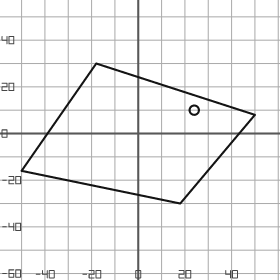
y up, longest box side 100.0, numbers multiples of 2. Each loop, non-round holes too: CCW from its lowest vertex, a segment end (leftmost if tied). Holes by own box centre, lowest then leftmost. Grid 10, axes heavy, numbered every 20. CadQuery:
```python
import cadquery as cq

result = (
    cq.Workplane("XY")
    .moveTo(18.0, -30.0)
    .lineTo(50.0, 8.0)
    .lineTo(-18.0, 30.0)
    .lineTo(-50.0, -16.0)
    .close()
    .moveTo(24.0, 10.0)
    .circle(2.0)
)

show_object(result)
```